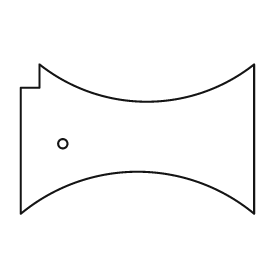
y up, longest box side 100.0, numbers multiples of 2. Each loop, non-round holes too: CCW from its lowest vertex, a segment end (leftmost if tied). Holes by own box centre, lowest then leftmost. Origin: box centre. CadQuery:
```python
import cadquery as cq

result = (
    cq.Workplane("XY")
    .moveTo(-50.0, -32.0)
    .threePointArc((0.0, -14.0), (50.0, -32.0))
    .lineTo(50.0, 32.0)
    .threePointArc((4.0, 16.0), (-42.0, 32.0))
    .lineTo(-42.0, 22.0)
    .lineTo(-50.0, 22.0)
    .close()
    .moveTo(-32.0, -2.0)
    .circle(2.0)
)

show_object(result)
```